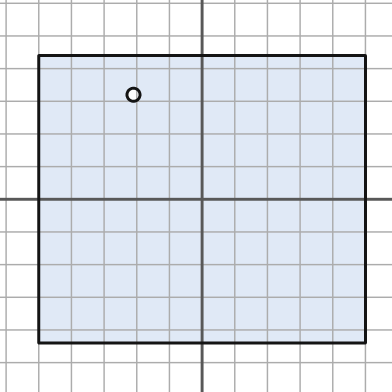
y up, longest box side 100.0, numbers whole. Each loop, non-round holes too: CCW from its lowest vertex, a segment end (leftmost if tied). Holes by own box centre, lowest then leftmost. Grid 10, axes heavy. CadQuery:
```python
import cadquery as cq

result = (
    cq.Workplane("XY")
    .moveTo(-50.0, -44.0)
    .lineTo(50.0, -44.0)
    .lineTo(50.0, 44.0)
    .lineTo(-50.0, 44.0)
    .close()
    .moveTo(-21.0, 32.0)
    .circle(2.0)
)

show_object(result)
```